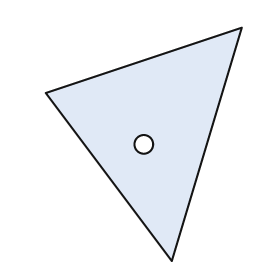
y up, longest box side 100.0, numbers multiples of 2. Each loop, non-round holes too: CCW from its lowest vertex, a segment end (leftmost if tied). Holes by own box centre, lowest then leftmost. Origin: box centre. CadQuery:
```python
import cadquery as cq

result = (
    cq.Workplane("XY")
    .moveTo(12.0, -50.0)
    .lineTo(42.0, 50.0)
    .lineTo(-42.0, 22.0)
    .close()
    .moveTo(0.0, 0.0)
    .circle(4.0)
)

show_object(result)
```